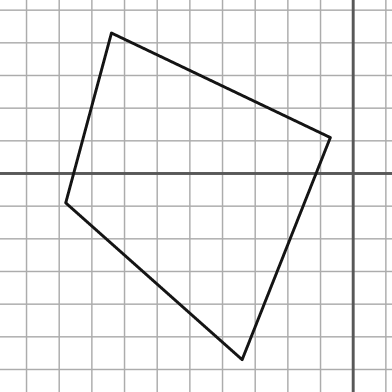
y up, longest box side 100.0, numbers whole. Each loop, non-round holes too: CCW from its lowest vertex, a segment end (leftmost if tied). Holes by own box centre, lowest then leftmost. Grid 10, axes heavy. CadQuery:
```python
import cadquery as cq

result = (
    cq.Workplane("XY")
    .moveTo(-34.0, -57.0)
    .lineTo(-7.0, 11.0)
    .lineTo(-74.0, 43.0)
    .lineTo(-88.0, -9.0)
    .close()
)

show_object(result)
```